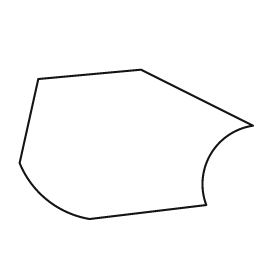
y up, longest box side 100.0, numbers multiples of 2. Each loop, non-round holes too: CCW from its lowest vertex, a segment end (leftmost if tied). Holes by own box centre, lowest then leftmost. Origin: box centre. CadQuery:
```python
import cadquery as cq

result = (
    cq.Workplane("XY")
    .moveTo(-20.0, -32.0)
    .lineTo(30.0, -26.0)
    .threePointArc((32.0, -4.0), (50.0, 8.0))
    .lineTo(2.0, 32.0)
    .lineTo(-42.0, 28.0)
    .lineTo(-50.0, -8.0)
    .threePointArc((-38.0, -24.0), (-20.0, -32.0))
    .close()
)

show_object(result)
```